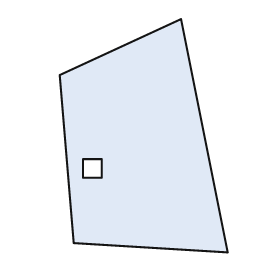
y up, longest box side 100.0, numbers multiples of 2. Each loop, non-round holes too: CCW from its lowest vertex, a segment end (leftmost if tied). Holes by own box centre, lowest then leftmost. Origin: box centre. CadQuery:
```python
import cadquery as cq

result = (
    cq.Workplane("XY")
    .moveTo(36.0, -50.0)
    .lineTo(16.0, 50.0)
    .lineTo(-36.0, 26.0)
    .lineTo(-30.0, -46.0)
    .close()
    .moveTo(-26.0, -18.0)
    .lineTo(-18.0, -18.0)
    .lineTo(-18.0, -10.0)
    .lineTo(-26.0, -10.0)
    .close()
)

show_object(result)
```